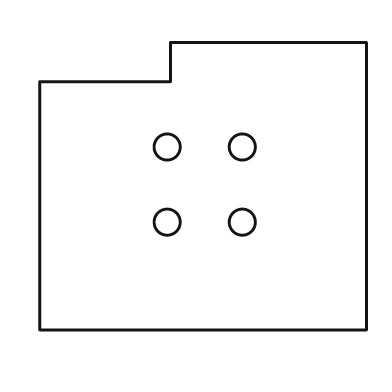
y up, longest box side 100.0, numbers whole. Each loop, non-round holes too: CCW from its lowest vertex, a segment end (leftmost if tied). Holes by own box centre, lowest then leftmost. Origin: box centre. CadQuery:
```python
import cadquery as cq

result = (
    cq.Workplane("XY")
    .moveTo(-50.0, -44.0)
    .lineTo(50.0, -44.0)
    .lineTo(50.0, 44.0)
    .lineTo(-10.0, 44.0)
    .lineTo(-10.0, 32.0)
    .lineTo(-50.0, 32.0)
    .close()
    .moveTo(-11.0, -11.0)
    .circle(4.0)
    .moveTo(12.0, -11.0)
    .circle(4.0)
    .moveTo(-11.0, 12.0)
    .circle(4.0)
    .moveTo(12.0, 12.0)
    .circle(4.0)
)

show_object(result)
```